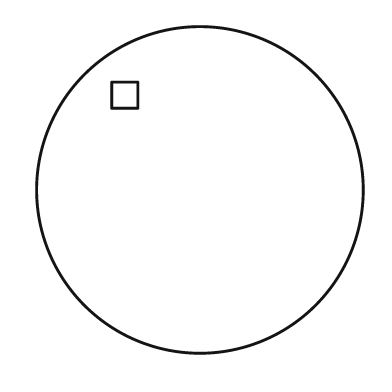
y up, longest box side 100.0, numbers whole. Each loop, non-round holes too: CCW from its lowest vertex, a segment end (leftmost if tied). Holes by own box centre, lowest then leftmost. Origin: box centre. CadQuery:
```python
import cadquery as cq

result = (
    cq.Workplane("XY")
    .moveTo(0.0, 0.0)
    .circle(50.0)
    .moveTo(-27.0, 25.0)
    .lineTo(-19.0, 25.0)
    .lineTo(-19.0, 33.0)
    .lineTo(-27.0, 33.0)
    .close()
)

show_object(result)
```